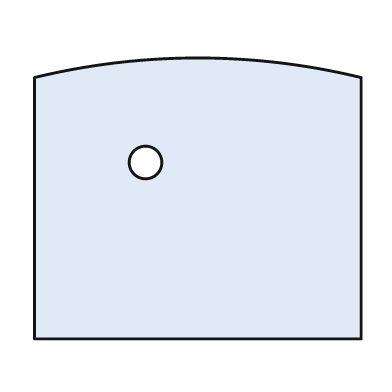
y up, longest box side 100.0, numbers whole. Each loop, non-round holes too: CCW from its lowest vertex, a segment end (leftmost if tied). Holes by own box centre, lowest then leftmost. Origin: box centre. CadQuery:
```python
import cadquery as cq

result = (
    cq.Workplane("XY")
    .moveTo(-50.0, -43.0)
    .lineTo(50.0, -43.0)
    .lineTo(50.0, 37.0)
    .threePointArc((0.0, 43.0), (-50.0, 37.0))
    .close()
    .moveTo(-16.0, 11.0)
    .circle(5.0)
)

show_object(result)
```